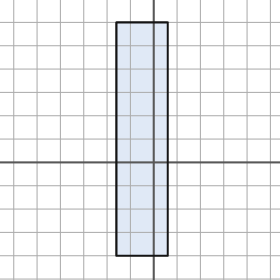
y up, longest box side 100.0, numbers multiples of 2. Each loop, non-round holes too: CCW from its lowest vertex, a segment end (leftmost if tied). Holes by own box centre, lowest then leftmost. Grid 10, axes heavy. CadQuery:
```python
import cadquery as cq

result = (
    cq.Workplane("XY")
    .moveTo(-16.0, -40.0)
    .lineTo(6.0, -40.0)
    .lineTo(6.0, 60.0)
    .lineTo(-16.0, 60.0)
    .close()
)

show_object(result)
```